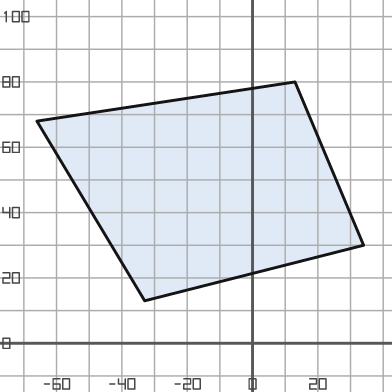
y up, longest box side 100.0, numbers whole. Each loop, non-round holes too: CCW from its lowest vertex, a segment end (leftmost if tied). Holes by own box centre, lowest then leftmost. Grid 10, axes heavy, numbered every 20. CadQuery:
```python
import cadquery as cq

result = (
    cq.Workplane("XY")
    .moveTo(-33.0, 13.0)
    .lineTo(34.0, 30.0)
    .lineTo(13.0, 80.0)
    .lineTo(-66.0, 68.0)
    .close()
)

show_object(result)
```